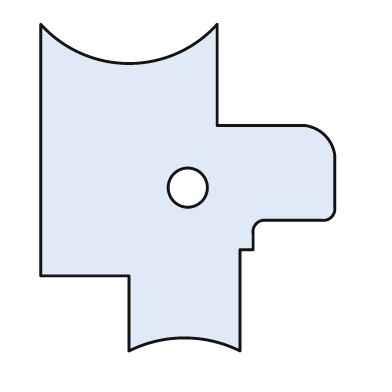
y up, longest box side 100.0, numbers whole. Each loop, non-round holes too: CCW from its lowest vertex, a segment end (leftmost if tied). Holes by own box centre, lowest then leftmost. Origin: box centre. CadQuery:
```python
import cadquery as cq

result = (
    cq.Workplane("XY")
    .moveTo(-18.0, -50.0)
    .threePointArc((-1.0, -46.0), (16.0, -50.0))
    .lineTo(16.0, -19.0)
    .lineTo(20.0, -19.0)
    .lineTo(20.0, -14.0)
    .threePointArc((21.0, -11.0), (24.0, -10.0))
    .lineTo(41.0, -10.0)
    .threePointArc((44.0, -9.0), (45.0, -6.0))
    .lineTo(45.0, 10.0)
    .threePointArc((42.0, 16.0), (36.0, 19.0))
    .lineTo(9.0, 19.0)
    .lineTo(9.0, 50.0)
    .threePointArc((-18.0, 38.0), (-45.0, 50.0))
    .lineTo(-45.0, -27.0)
    .lineTo(-18.0, -27.0)
    .close()
    .moveTo(0.0, 0.0)
    .circle(6.0)
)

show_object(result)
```